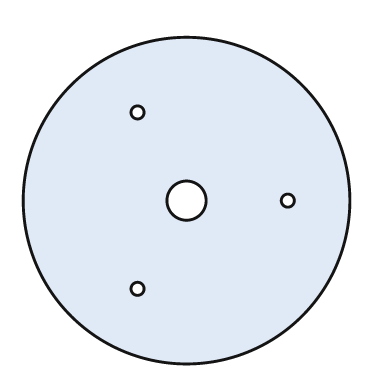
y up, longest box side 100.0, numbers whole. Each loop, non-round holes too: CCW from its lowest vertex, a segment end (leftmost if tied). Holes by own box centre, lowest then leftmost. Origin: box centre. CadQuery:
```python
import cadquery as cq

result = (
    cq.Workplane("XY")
    .moveTo(0.0, 0.0)
    .circle(50.0)
    .moveTo(-15.0, -27.0)
    .circle(2.0)
    .moveTo(0.0, 0.0)
    .circle(6.0)
    .moveTo(31.0, 0.0)
    .circle(2.0)
    .moveTo(-15.0, 27.0)
    .circle(2.0)
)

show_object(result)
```